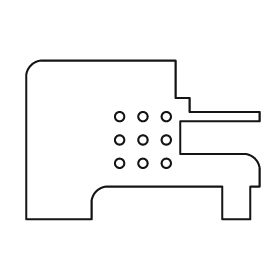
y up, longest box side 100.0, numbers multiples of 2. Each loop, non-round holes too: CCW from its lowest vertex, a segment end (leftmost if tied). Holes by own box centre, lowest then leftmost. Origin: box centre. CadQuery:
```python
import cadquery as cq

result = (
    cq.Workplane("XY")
    .moveTo(-50.0, -34.0)
    .lineTo(-22.0, -34.0)
    .lineTo(-22.0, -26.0)
    .threePointArc((-20.0, -22.0), (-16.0, -20.0))
    .lineTo(34.0, -20.0)
    .lineTo(34.0, -34.0)
    .lineTo(46.0, -34.0)
    .lineTo(46.0, -20.0)
    .lineTo(50.0, -20.0)
    .lineTo(50.0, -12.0)
    .threePointArc((48.0, -8.0), (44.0, -6.0))
    .lineTo(16.0, -6.0)
    .lineTo(16.0, 8.0)
    .lineTo(50.0, 8.0)
    .lineTo(50.0, 12.0)
    .lineTo(20.0, 12.0)
    .lineTo(20.0, 18.0)
    .lineTo(14.0, 18.0)
    .lineTo(14.0, 34.0)
    .lineTo(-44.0, 34.0)
    .threePointArc((-48.0, 32.0), (-50.0, 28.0))
    .close()
    .moveTo(-10.0, -10.0)
    .circle(2.0)
    .moveTo(0.0, -10.0)
    .circle(2.0)
    .moveTo(10.0, -10.0)
    .circle(2.0)
    .moveTo(-10.0, 0.0)
    .circle(2.0)
    .moveTo(0.0, 0.0)
    .circle(2.0)
    .moveTo(10.0, 0.0)
    .circle(2.0)
    .moveTo(-10.0, 10.0)
    .circle(2.0)
    .moveTo(0.0, 10.0)
    .circle(2.0)
    .moveTo(10.0, 10.0)
    .circle(2.0)
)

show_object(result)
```